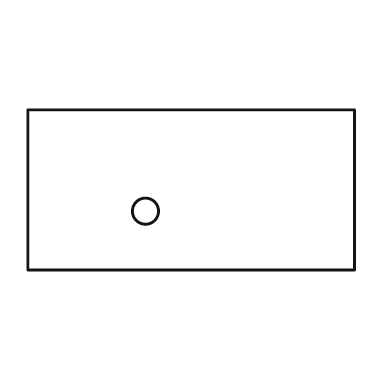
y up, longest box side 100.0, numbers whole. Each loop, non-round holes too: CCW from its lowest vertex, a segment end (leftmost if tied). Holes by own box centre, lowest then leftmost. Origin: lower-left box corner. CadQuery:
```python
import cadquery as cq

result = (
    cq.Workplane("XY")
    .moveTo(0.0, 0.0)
    .lineTo(100.0, 0.0)
    .lineTo(100.0, 49.0)
    .lineTo(0.0, 49.0)
    .close()
    .moveTo(36.0, 18.0)
    .circle(4.0)
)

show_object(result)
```